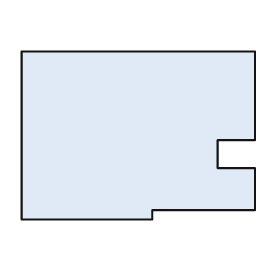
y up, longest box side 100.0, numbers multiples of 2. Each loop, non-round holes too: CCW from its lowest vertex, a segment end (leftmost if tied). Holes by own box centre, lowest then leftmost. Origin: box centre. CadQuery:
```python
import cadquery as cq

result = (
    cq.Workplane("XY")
    .moveTo(-50.0, -36.0)
    .lineTo(6.0, -36.0)
    .lineTo(6.0, -32.0)
    .lineTo(50.0, -32.0)
    .lineTo(50.0, -14.0)
    .lineTo(34.0, -14.0)
    .lineTo(34.0, -2.0)
    .lineTo(50.0, -2.0)
    .lineTo(50.0, 36.0)
    .lineTo(-50.0, 36.0)
    .close()
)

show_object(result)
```